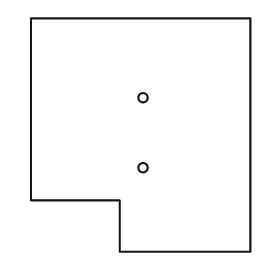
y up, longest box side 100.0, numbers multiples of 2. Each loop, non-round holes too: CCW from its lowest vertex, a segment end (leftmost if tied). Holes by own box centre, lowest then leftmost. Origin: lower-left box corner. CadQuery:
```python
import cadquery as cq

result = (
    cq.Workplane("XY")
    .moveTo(38.0, 0.0)
    .lineTo(94.0, 0.0)
    .lineTo(94.0, 100.0)
    .lineTo(0.0, 100.0)
    .lineTo(0.0, 22.0)
    .lineTo(38.0, 22.0)
    .close()
    .moveTo(48.0, 36.0)
    .circle(2.0)
    .moveTo(48.0, 66.0)
    .circle(2.0)
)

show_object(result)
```